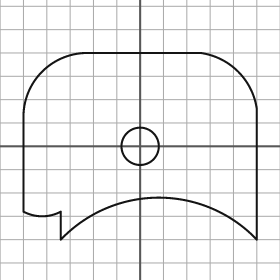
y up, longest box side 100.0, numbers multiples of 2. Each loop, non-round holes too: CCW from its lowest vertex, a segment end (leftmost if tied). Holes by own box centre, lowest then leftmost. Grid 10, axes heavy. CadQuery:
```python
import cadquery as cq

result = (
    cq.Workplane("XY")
    .moveTo(-34.0, -40.0)
    .threePointArc((8.0, -22.0), (50.0, -40.0))
    .lineTo(50.0, 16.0)
    .threePointArc((42.0, 32.0), (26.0, 40.0))
    .lineTo(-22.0, 40.0)
    .threePointArc((-42.0, 32.0), (-50.0, 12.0))
    .lineTo(-50.0, -28.0)
    .threePointArc((-42.0, -30.0), (-34.0, -28.0))
    .close()
    .moveTo(0.0, 0.0)
    .circle(8.0)
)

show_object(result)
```